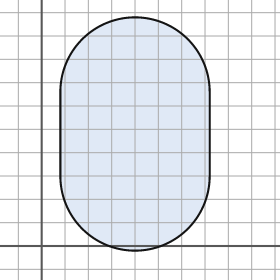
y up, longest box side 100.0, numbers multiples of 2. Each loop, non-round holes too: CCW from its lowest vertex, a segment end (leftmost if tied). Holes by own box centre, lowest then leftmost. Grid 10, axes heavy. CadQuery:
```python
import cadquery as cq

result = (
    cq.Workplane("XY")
    .moveTo(8.0, 30.0)
    .threePointArc((40.0, -2.0), (72.0, 30.0))
    .lineTo(72.0, 66.0)
    .threePointArc((40.0, 98.0), (8.0, 66.0))
    .close()
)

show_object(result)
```